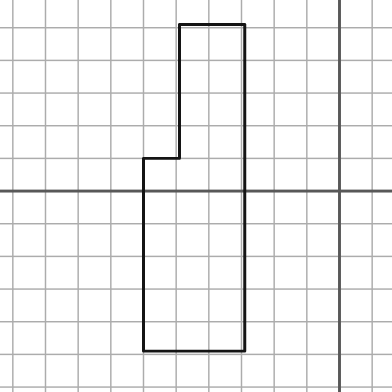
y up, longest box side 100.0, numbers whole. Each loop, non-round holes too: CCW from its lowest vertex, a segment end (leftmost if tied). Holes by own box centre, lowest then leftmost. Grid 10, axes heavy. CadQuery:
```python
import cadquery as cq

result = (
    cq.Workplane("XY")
    .moveTo(-60.0, -49.0)
    .lineTo(-29.0, -49.0)
    .lineTo(-29.0, 51.0)
    .lineTo(-49.0, 51.0)
    .lineTo(-49.0, 10.0)
    .lineTo(-60.0, 10.0)
    .close()
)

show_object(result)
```